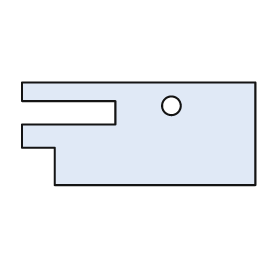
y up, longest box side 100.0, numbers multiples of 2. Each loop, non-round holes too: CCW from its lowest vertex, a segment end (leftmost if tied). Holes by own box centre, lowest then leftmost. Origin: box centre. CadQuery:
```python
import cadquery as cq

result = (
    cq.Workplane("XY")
    .moveTo(-36.0, -22.0)
    .lineTo(50.0, -22.0)
    .lineTo(50.0, 22.0)
    .lineTo(-50.0, 22.0)
    .lineTo(-50.0, 14.0)
    .lineTo(-10.0, 14.0)
    .lineTo(-10.0, 4.0)
    .lineTo(-50.0, 4.0)
    .lineTo(-50.0, -6.0)
    .lineTo(-36.0, -6.0)
    .close()
    .moveTo(14.0, 12.0)
    .circle(4.0)
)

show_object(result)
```